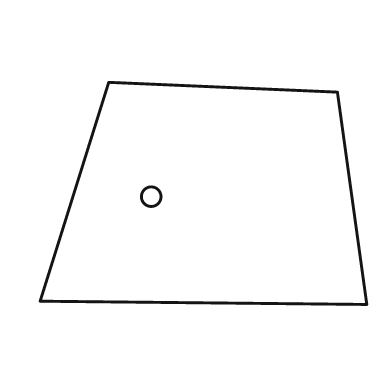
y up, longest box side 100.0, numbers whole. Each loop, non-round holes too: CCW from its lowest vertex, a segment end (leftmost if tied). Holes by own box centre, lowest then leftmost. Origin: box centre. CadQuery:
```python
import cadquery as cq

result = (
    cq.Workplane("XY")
    .moveTo(50.0, -34.0)
    .lineTo(41.0, 31.0)
    .lineTo(-29.0, 34.0)
    .lineTo(-50.0, -33.0)
    .close()
    .moveTo(-16.0, -1.0)
    .circle(3.0)
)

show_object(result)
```